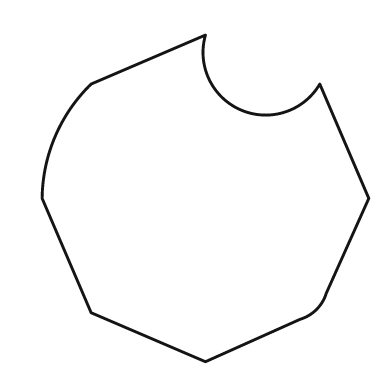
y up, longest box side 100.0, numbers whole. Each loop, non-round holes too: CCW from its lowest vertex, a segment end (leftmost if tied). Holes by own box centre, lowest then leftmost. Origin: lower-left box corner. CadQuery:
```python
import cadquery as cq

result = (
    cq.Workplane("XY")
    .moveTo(50.0, 0.0)
    .lineTo(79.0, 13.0)
    .threePointArc((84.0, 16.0), (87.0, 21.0))
    .lineTo(100.0, 50.0)
    .lineTo(85.0, 85.0)
    .threePointArc((61.0, 77.0), (50.0, 100.0))
    .lineTo(15.0, 85.0)
    .threePointArc((4.0, 69.0), (0.0, 50.0))
    .lineTo(15.0, 15.0)
    .close()
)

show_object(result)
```